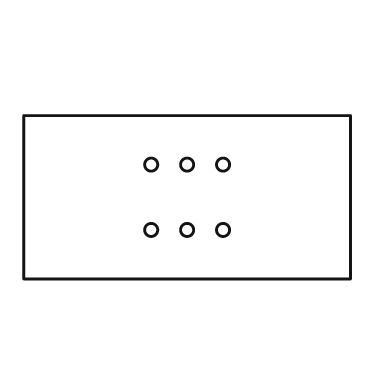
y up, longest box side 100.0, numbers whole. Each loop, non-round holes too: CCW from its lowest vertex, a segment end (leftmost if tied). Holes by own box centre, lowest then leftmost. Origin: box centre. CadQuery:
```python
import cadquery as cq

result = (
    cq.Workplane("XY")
    .moveTo(-50.0, -25.0)
    .lineTo(50.0, -25.0)
    .lineTo(50.0, 25.0)
    .lineTo(-50.0, 25.0)
    .close()
    .moveTo(-11.0, -10.0)
    .circle(2.0)
    .moveTo(0.0, -10.0)
    .circle(2.0)
    .moveTo(11.0, -10.0)
    .circle(2.0)
    .moveTo(-11.0, 10.0)
    .circle(2.0)
    .moveTo(0.0, 10.0)
    .circle(2.0)
    .moveTo(11.0, 10.0)
    .circle(2.0)
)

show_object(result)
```